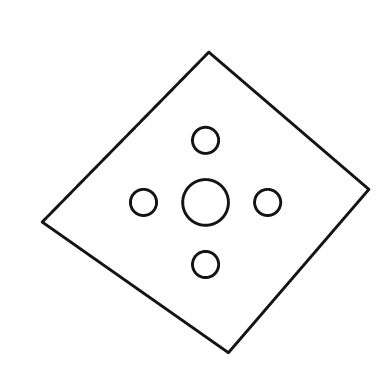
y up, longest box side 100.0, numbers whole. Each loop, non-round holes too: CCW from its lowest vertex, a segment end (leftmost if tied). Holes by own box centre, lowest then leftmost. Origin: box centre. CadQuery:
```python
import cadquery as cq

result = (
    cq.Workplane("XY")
    .moveTo(7.0, -46.0)
    .lineTo(50.0, 4.0)
    .lineTo(1.0, 46.0)
    .lineTo(-50.0, -6.0)
    .close()
    .moveTo(0.0, -19.0)
    .circle(4.0)
    .moveTo(-19.0, 0.0)
    .circle(4.0)
    .moveTo(0.0, 0.0)
    .circle(7.0)
    .moveTo(19.0, 0.0)
    .circle(4.0)
    .moveTo(0.0, 19.0)
    .circle(4.0)
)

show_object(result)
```